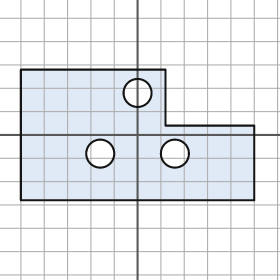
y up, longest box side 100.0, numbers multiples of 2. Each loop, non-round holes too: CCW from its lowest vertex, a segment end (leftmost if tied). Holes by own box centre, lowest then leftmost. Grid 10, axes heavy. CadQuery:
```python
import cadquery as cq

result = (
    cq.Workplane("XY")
    .moveTo(-50.0, -28.0)
    .lineTo(50.0, -28.0)
    .lineTo(50.0, 4.0)
    .lineTo(12.0, 4.0)
    .lineTo(12.0, 28.0)
    .lineTo(-50.0, 28.0)
    .close()
    .moveTo(-16.0, -8.0)
    .circle(6.0)
    .moveTo(16.0, -8.0)
    .circle(6.0)
    .moveTo(0.0, 18.0)
    .circle(6.0)
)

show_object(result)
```